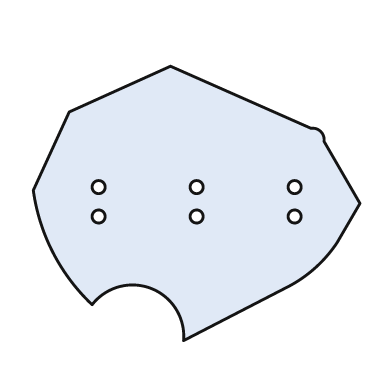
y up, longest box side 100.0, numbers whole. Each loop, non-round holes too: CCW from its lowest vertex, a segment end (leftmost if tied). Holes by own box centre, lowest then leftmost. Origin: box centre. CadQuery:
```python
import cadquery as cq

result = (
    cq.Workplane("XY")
    .moveTo(-4.0, -42.0)
    .lineTo(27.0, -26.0)
    .threePointArc((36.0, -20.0), (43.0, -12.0))
    .lineTo(50.0, 0.0)
    .lineTo(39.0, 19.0)
    .threePointArc((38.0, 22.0), (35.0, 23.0))
    .lineTo(-8.0, 42.0)
    .lineTo(-39.0, 28.0)
    .lineTo(-50.0, 4.0)
    .threePointArc((-44.0, -15.0), (-32.0, -31.0))
    .threePointArc((-14.0, -26.0), (-4.0, -42.0))
    .close()
    .moveTo(-30.0, -4.0)
    .circle(2.0)
    .moveTo(0.0, -4.0)
    .circle(2.0)
    .moveTo(30.0, -4.0)
    .circle(2.0)
    .moveTo(-30.0, 5.0)
    .circle(2.0)
    .moveTo(0.0, 5.0)
    .circle(2.0)
    .moveTo(30.0, 5.0)
    .circle(2.0)
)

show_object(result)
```